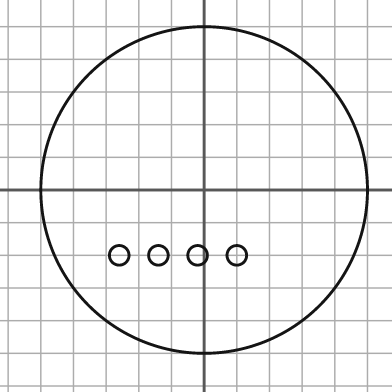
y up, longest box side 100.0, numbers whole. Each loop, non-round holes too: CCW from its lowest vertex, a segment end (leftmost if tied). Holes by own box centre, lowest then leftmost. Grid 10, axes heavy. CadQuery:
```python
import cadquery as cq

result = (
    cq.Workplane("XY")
    .moveTo(0.0, 0.0)
    .circle(50.0)
    .moveTo(-26.0, -20.0)
    .circle(3.0)
    .moveTo(-14.0, -20.0)
    .circle(3.0)
    .moveTo(-2.0, -20.0)
    .circle(3.0)
    .moveTo(10.0, -20.0)
    .circle(3.0)
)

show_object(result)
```